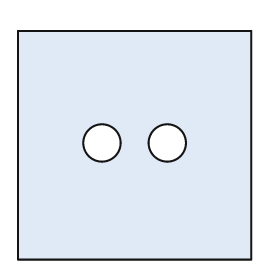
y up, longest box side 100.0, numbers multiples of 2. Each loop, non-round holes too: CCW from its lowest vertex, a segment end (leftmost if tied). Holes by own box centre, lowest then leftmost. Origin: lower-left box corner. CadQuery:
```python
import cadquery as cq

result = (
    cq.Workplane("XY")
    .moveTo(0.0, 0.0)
    .lineTo(100.0, 0.0)
    .lineTo(100.0, 98.0)
    .lineTo(0.0, 98.0)
    .close()
    .moveTo(36.0, 50.0)
    .circle(8.0)
    .moveTo(64.0, 50.0)
    .circle(8.0)
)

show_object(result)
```